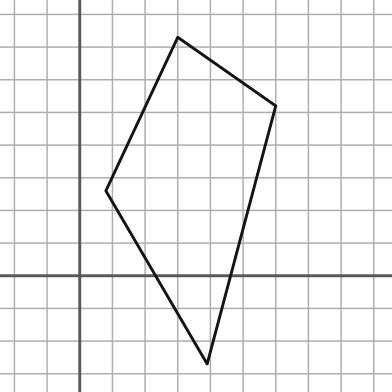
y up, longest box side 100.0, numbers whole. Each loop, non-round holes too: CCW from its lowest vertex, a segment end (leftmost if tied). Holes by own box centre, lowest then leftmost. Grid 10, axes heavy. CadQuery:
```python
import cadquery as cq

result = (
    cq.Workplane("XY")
    .moveTo(39.0, -27.0)
    .lineTo(60.0, 52.0)
    .lineTo(30.0, 73.0)
    .lineTo(8.0, 26.0)
    .close()
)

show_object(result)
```